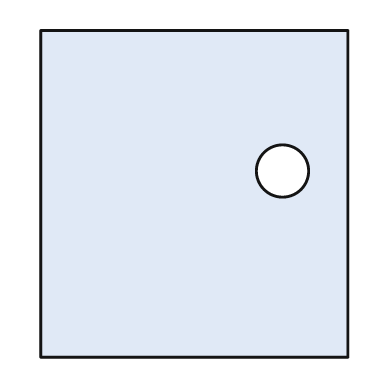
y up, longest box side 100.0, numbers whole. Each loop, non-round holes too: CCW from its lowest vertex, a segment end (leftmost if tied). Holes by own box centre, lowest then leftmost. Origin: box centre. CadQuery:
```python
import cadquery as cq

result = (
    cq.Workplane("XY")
    .moveTo(-47.0, -50.0)
    .lineTo(47.0, -50.0)
    .lineTo(47.0, 50.0)
    .lineTo(-47.0, 50.0)
    .close()
    .moveTo(27.0, 7.0)
    .circle(8.0)
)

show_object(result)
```